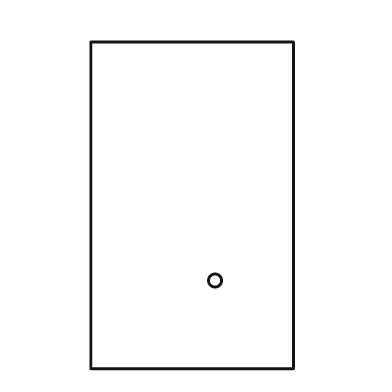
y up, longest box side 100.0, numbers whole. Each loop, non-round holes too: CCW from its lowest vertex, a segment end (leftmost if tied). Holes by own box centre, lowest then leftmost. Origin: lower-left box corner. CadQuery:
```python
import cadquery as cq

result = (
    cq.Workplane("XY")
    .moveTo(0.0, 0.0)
    .lineTo(62.0, 0.0)
    .lineTo(62.0, 100.0)
    .lineTo(0.0, 100.0)
    .close()
    .moveTo(38.0, 27.0)
    .circle(2.0)
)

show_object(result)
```